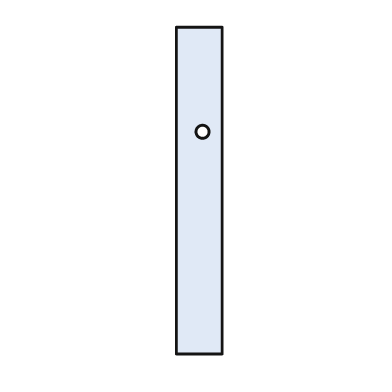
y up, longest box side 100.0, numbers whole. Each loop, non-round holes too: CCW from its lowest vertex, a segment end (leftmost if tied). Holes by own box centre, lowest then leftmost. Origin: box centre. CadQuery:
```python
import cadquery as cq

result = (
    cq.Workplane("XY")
    .moveTo(-7.0, -50.0)
    .lineTo(7.0, -50.0)
    .lineTo(7.0, 50.0)
    .lineTo(-7.0, 50.0)
    .close()
    .moveTo(1.0, 18.0)
    .circle(2.0)
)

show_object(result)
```